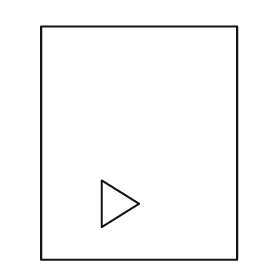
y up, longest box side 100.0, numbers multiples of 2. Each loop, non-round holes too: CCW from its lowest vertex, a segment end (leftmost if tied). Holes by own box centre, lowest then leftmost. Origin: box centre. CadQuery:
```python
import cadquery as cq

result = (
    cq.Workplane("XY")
    .moveTo(-42.0, -50.0)
    .lineTo(42.0, -50.0)
    .lineTo(42.0, 50.0)
    .lineTo(-42.0, 50.0)
    .close()
    .moveTo(-16.0, -36.0)
    .lineTo(0.0, -26.0)
    .lineTo(-16.0, -16.0)
    .close()
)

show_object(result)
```